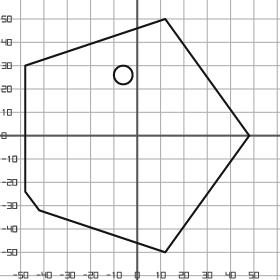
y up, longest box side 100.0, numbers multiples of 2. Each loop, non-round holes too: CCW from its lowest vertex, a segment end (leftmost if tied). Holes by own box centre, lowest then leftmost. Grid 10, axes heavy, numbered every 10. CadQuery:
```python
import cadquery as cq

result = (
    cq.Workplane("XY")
    .moveTo(12.0, -50.0)
    .lineTo(48.0, 0.0)
    .lineTo(12.0, 50.0)
    .lineTo(-48.0, 30.0)
    .lineTo(-48.0, -24.0)
    .lineTo(-42.0, -32.0)
    .close()
    .moveTo(-6.0, 26.0)
    .circle(4.0)
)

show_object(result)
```